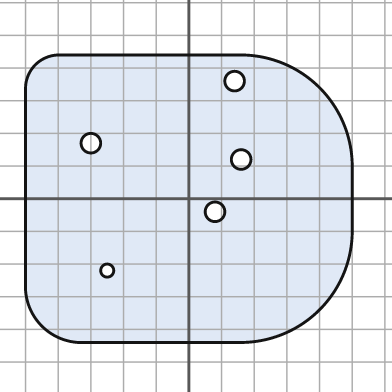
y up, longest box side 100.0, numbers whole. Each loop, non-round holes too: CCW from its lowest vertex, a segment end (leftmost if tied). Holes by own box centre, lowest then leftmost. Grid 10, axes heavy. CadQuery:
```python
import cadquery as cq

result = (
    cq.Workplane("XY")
    .moveTo(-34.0, -44.0)
    .lineTo(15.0, -44.0)
    .threePointArc((40.0, -34.0), (50.0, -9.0))
    .lineTo(50.0, 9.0)
    .threePointArc((40.0, 34.0), (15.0, 44.0))
    .lineTo(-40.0, 44.0)
    .threePointArc((-47.0, 41.0), (-50.0, 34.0))
    .lineTo(-50.0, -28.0)
    .threePointArc((-45.0, -39.0), (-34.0, -44.0))
    .close()
    .moveTo(-25.0, -22.0)
    .circle(2.0)
    .moveTo(8.0, -4.0)
    .circle(3.0)
    .moveTo(16.0, 12.0)
    .circle(3.0)
    .moveTo(-30.0, 17.0)
    .circle(3.0)
    .moveTo(14.0, 36.0)
    .circle(3.0)
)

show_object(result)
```